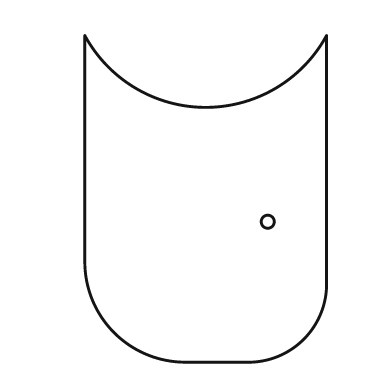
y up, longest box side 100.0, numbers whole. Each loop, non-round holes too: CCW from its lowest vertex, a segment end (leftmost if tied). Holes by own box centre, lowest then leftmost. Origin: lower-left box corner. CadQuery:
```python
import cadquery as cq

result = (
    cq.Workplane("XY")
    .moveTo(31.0, 0.0)
    .lineTo(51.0, 0.0)
    .threePointArc((67.0, 7.0), (74.0, 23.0))
    .lineTo(74.0, 100.0)
    .threePointArc((37.0, 78.0), (0.0, 100.0))
    .lineTo(0.0, 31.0)
    .threePointArc((9.0, 9.0), (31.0, 0.0))
    .close()
    .moveTo(56.0, 43.0)
    .circle(2.0)
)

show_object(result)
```